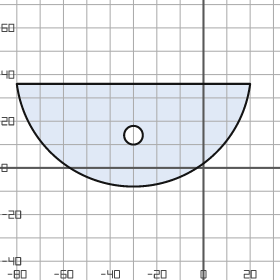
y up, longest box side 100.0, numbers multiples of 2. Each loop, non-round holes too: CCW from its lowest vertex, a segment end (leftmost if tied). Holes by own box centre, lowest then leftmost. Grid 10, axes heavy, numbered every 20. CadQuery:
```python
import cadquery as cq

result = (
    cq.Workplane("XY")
    .moveTo(-80.0, 36.0)
    .threePointArc((-30.0, -8.0), (20.0, 36.0))
    .close()
    .moveTo(-30.0, 14.0)
    .circle(4.0)
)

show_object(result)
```